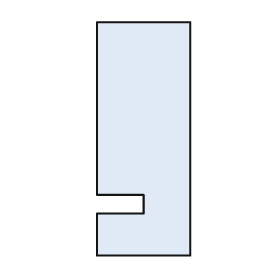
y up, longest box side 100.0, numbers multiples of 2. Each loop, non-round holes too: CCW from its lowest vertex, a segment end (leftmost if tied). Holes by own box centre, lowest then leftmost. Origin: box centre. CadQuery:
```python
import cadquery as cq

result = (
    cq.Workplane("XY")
    .moveTo(-20.0, -50.0)
    .lineTo(20.0, -50.0)
    .lineTo(20.0, 50.0)
    .lineTo(-20.0, 50.0)
    .lineTo(-20.0, -24.0)
    .lineTo(0.0, -24.0)
    .lineTo(0.0, -32.0)
    .lineTo(-20.0, -32.0)
    .close()
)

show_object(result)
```